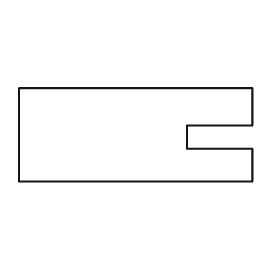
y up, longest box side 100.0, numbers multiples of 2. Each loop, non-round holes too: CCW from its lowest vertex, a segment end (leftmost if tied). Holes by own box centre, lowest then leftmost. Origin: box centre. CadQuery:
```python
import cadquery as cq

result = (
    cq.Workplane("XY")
    .moveTo(-50.0, -20.0)
    .lineTo(50.0, -20.0)
    .lineTo(50.0, -6.0)
    .lineTo(22.0, -6.0)
    .lineTo(22.0, 4.0)
    .lineTo(50.0, 4.0)
    .lineTo(50.0, 20.0)
    .lineTo(-50.0, 20.0)
    .close()
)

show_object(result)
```